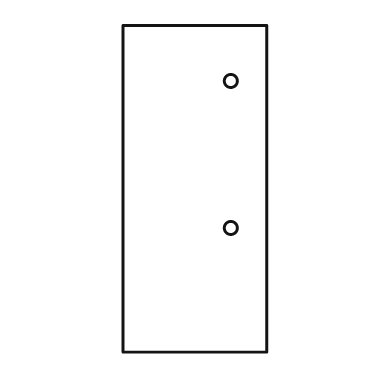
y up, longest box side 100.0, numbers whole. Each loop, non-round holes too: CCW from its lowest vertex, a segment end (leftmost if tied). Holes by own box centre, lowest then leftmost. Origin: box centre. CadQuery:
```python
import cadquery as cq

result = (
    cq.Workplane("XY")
    .moveTo(-22.0, -50.0)
    .lineTo(22.0, -50.0)
    .lineTo(22.0, 50.0)
    .lineTo(-22.0, 50.0)
    .close()
    .moveTo(11.0, -12.0)
    .circle(2.0)
    .moveTo(11.0, 33.0)
    .circle(2.0)
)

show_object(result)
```